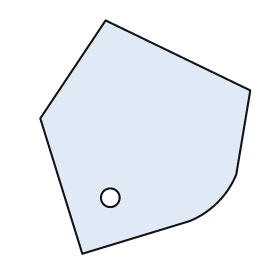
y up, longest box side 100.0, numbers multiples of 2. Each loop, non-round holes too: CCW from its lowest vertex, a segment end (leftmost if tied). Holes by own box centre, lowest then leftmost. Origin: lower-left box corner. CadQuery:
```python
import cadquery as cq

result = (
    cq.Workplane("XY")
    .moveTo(18.0, 0.0)
    .lineTo(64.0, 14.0)
    .threePointArc((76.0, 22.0), (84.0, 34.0))
    .lineTo(90.0, 70.0)
    .lineTo(28.0, 100.0)
    .lineTo(0.0, 58.0)
    .close()
    .moveTo(30.0, 24.0)
    .circle(4.0)
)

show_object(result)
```